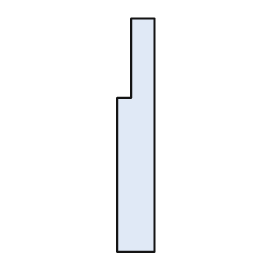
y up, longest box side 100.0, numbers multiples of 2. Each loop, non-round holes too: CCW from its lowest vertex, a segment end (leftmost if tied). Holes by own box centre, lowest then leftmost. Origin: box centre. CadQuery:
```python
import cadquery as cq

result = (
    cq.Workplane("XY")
    .moveTo(-8.0, -50.0)
    .lineTo(8.0, -50.0)
    .lineTo(8.0, 50.0)
    .lineTo(-2.0, 50.0)
    .lineTo(-2.0, 16.0)
    .lineTo(-8.0, 16.0)
    .close()
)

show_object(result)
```